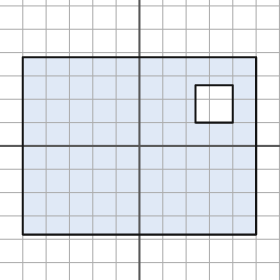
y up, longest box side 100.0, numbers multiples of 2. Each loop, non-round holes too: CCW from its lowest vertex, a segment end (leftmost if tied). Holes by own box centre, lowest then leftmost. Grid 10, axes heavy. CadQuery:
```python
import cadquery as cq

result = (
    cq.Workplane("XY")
    .moveTo(-50.0, -38.0)
    .lineTo(50.0, -38.0)
    .lineTo(50.0, 38.0)
    .lineTo(-50.0, 38.0)
    .close()
    .moveTo(24.0, 10.0)
    .lineTo(40.0, 10.0)
    .lineTo(40.0, 26.0)
    .lineTo(24.0, 26.0)
    .close()
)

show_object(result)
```